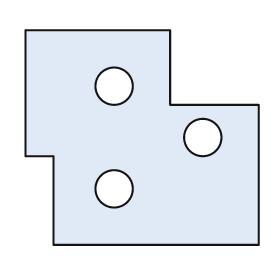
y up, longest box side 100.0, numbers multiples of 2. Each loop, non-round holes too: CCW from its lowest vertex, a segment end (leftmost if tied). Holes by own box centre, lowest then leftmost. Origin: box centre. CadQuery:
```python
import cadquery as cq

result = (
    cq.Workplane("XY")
    .moveTo(-38.0, -46.0)
    .lineTo(50.0, -46.0)
    .lineTo(50.0, 14.0)
    .lineTo(12.0, 14.0)
    .lineTo(12.0, 46.0)
    .lineTo(-50.0, 46.0)
    .lineTo(-50.0, -8.0)
    .lineTo(-38.0, -8.0)
    .close()
    .moveTo(-12.0, -22.0)
    .circle(8.0)
    .moveTo(26.0, 0.0)
    .circle(8.0)
    .moveTo(-12.0, 22.0)
    .circle(8.0)
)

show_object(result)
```